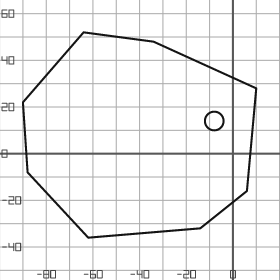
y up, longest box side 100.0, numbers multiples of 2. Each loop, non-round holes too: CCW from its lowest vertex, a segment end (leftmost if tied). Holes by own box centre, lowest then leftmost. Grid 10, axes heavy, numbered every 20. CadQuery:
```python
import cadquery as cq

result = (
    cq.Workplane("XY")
    .moveTo(-62.0, -36.0)
    .lineTo(-14.0, -32.0)
    .lineTo(6.0, -16.0)
    .lineTo(10.0, 28.0)
    .lineTo(-34.0, 48.0)
    .lineTo(-64.0, 52.0)
    .lineTo(-90.0, 22.0)
    .lineTo(-88.0, -8.0)
    .close()
    .moveTo(-8.0, 14.0)
    .circle(4.0)
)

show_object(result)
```